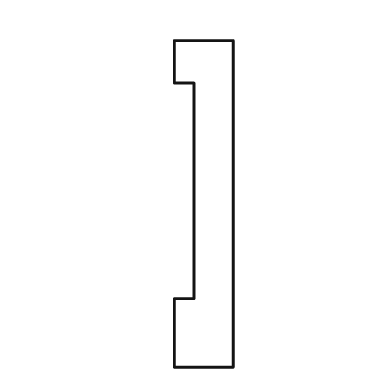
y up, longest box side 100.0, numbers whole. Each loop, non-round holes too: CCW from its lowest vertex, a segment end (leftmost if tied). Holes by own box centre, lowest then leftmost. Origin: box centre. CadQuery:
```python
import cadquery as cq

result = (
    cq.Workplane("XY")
    .moveTo(-9.0, -50.0)
    .lineTo(9.0, -50.0)
    .lineTo(9.0, 50.0)
    .lineTo(-9.0, 50.0)
    .lineTo(-9.0, 37.0)
    .lineTo(-3.0, 37.0)
    .lineTo(-3.0, -29.0)
    .lineTo(-9.0, -29.0)
    .close()
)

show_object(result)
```